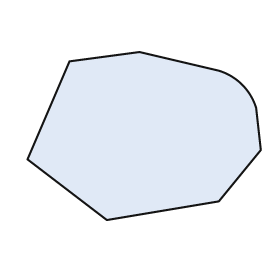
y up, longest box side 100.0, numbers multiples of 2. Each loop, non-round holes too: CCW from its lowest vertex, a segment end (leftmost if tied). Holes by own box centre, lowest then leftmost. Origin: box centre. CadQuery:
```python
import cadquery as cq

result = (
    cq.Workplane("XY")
    .moveTo(-16.0, -36.0)
    .lineTo(32.0, -28.0)
    .lineTo(50.0, -6.0)
    .lineTo(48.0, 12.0)
    .threePointArc((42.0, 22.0), (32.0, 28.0))
    .lineTo(-2.0, 36.0)
    .lineTo(-32.0, 32.0)
    .lineTo(-50.0, -10.0)
    .close()
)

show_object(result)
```